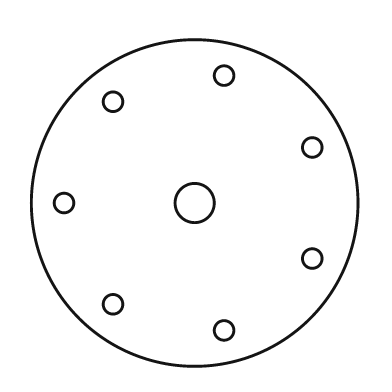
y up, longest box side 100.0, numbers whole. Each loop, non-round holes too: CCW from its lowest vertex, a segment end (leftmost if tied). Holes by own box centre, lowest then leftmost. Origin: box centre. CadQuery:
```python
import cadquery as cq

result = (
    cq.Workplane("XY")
    .moveTo(0.0, 0.0)
    .circle(50.0)
    .moveTo(9.0, -39.0)
    .circle(3.0)
    .moveTo(-25.0, -31.0)
    .circle(3.0)
    .moveTo(36.0, -17.0)
    .circle(3.0)
    .moveTo(-40.0, 0.0)
    .circle(3.0)
    .moveTo(0.0, 0.0)
    .circle(6.0)
    .moveTo(36.0, 17.0)
    .circle(3.0)
    .moveTo(-25.0, 31.0)
    .circle(3.0)
    .moveTo(9.0, 39.0)
    .circle(3.0)
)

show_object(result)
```